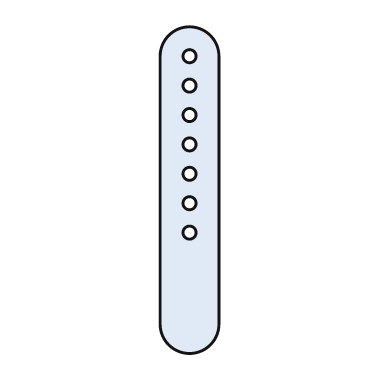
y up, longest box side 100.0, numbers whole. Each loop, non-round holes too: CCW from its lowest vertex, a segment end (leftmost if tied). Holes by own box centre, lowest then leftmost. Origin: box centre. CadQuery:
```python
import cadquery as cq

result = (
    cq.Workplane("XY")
    .moveTo(-9.0, -41.0)
    .threePointArc((0.0, -50.0), (9.0, -41.0))
    .lineTo(9.0, 41.0)
    .threePointArc((0.0, 50.0), (-9.0, 41.0))
    .close()
    .moveTo(0.0, -13.0)
    .circle(2.0)
    .moveTo(0.0, -4.0)
    .circle(2.0)
    .moveTo(0.0, 5.0)
    .circle(2.0)
    .moveTo(0.0, 14.0)
    .circle(2.0)
    .moveTo(0.0, 23.0)
    .circle(2.0)
    .moveTo(0.0, 32.0)
    .circle(2.0)
    .moveTo(0.0, 41.0)
    .circle(2.0)
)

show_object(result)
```